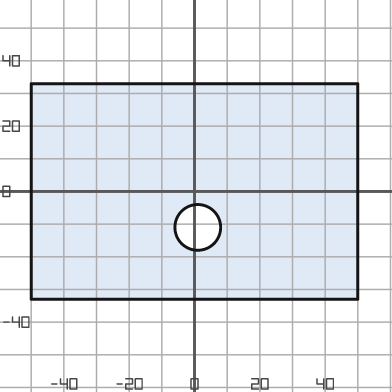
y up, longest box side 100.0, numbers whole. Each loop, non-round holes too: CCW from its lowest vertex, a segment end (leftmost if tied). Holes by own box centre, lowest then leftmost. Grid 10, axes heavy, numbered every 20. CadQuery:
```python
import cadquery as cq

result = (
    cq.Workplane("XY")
    .moveTo(-50.0, -33.0)
    .lineTo(50.0, -33.0)
    .lineTo(50.0, 33.0)
    .lineTo(-50.0, 33.0)
    .close()
    .moveTo(1.0, -11.0)
    .circle(7.0)
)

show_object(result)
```